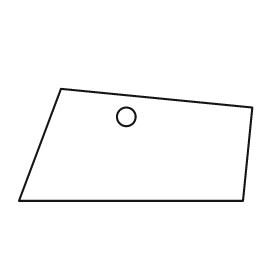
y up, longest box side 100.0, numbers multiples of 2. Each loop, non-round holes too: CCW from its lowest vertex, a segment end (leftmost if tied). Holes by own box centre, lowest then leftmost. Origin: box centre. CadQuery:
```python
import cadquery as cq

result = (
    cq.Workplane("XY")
    .moveTo(-50.0, -24.0)
    .lineTo(46.0, -24.0)
    .lineTo(50.0, 16.0)
    .lineTo(-32.0, 24.0)
    .close()
    .moveTo(-4.0, 12.0)
    .circle(4.0)
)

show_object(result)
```